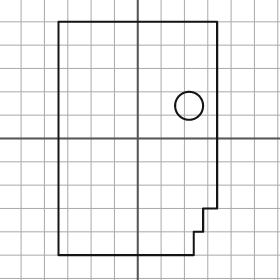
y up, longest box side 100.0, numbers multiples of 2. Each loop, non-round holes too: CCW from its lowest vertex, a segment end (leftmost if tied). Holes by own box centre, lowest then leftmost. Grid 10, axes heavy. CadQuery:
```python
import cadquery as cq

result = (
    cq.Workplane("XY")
    .moveTo(-34.0, -50.0)
    .lineTo(24.0, -50.0)
    .lineTo(24.0, -40.0)
    .lineTo(28.0, -40.0)
    .lineTo(28.0, -30.0)
    .lineTo(34.0, -30.0)
    .lineTo(34.0, 50.0)
    .lineTo(-34.0, 50.0)
    .close()
    .moveTo(22.0, 14.0)
    .circle(6.0)
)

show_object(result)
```